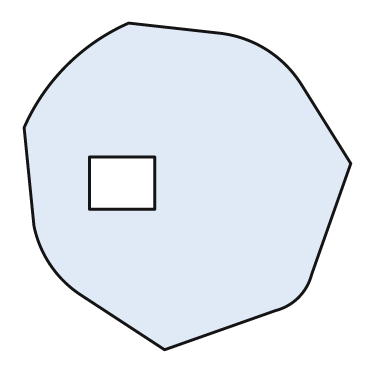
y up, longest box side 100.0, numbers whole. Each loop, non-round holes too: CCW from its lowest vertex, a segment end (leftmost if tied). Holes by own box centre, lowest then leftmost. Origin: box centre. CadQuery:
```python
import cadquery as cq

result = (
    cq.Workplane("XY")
    .moveTo(-7.0, -50.0)
    .lineTo(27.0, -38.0)
    .threePointArc((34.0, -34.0), (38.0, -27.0))
    .lineTo(50.0, 7.0)
    .lineTo(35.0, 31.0)
    .threePointArc((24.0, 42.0), (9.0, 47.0))
    .lineTo(-18.0, 50.0)
    .threePointArc((-37.0, 37.0), (-50.0, 18.0))
    .lineTo(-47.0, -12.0)
    .threePointArc((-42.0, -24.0), (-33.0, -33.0))
    .close()
    .moveTo(-30.0, -7.0)
    .lineTo(-10.0, -7.0)
    .lineTo(-10.0, 9.0)
    .lineTo(-30.0, 9.0)
    .close()
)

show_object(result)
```